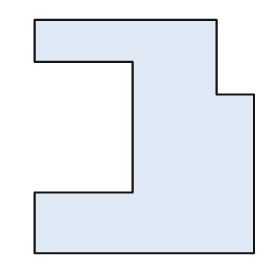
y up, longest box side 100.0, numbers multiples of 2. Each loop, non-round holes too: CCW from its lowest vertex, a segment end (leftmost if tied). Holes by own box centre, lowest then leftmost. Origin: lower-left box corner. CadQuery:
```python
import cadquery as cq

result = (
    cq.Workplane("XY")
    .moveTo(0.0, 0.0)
    .lineTo(94.0, 0.0)
    .lineTo(94.0, 68.0)
    .lineTo(78.0, 68.0)
    .lineTo(78.0, 100.0)
    .lineTo(0.0, 100.0)
    .lineTo(0.0, 82.0)
    .lineTo(42.0, 82.0)
    .lineTo(42.0, 26.0)
    .lineTo(0.0, 26.0)
    .close()
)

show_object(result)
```